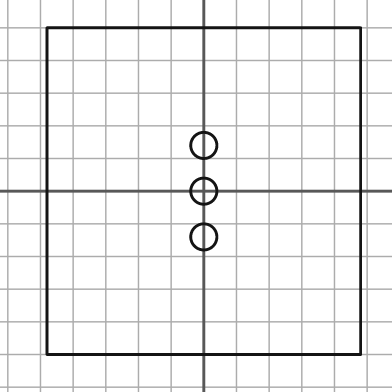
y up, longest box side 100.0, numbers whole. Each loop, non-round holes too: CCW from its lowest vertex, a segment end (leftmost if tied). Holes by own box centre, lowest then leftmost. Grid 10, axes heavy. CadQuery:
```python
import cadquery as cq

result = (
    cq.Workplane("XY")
    .moveTo(-48.0, -50.0)
    .lineTo(48.0, -50.0)
    .lineTo(48.0, 50.0)
    .lineTo(-48.0, 50.0)
    .close()
    .moveTo(0.0, -14.0)
    .circle(4.0)
    .moveTo(0.0, 0.0)
    .circle(4.0)
    .moveTo(0.0, 14.0)
    .circle(4.0)
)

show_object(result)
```